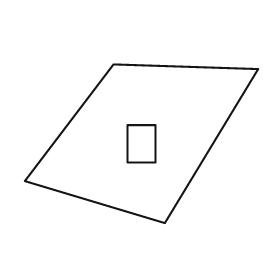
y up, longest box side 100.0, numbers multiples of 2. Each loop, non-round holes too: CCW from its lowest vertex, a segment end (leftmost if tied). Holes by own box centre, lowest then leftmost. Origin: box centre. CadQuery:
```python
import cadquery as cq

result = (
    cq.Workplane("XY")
    .moveTo(10.0, -34.0)
    .lineTo(50.0, 32.0)
    .lineTo(-12.0, 34.0)
    .lineTo(-50.0, -16.0)
    .close()
    .moveTo(-6.0, -8.0)
    .lineTo(6.0, -8.0)
    .lineTo(6.0, 8.0)
    .lineTo(-6.0, 8.0)
    .close()
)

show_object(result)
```